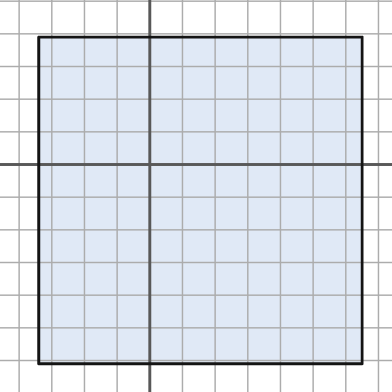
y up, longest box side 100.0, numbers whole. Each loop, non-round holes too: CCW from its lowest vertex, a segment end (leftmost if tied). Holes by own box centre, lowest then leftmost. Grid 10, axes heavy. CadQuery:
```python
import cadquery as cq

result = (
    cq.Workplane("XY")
    .moveTo(-34.0, -61.0)
    .lineTo(65.0, -61.0)
    .lineTo(65.0, 39.0)
    .lineTo(-34.0, 39.0)
    .close()
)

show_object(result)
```